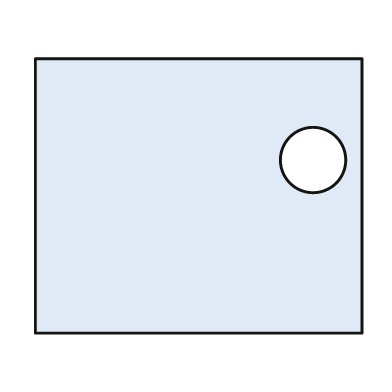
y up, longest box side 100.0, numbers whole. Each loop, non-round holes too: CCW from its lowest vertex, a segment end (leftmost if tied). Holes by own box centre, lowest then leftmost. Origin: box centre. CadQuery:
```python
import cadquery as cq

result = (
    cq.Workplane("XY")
    .moveTo(-50.0, -42.0)
    .lineTo(50.0, -42.0)
    .lineTo(50.0, 42.0)
    .lineTo(-50.0, 42.0)
    .close()
    .moveTo(35.0, 11.0)
    .circle(10.0)
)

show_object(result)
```